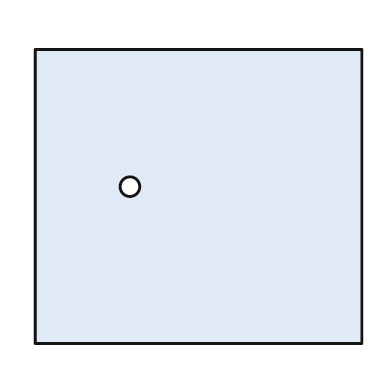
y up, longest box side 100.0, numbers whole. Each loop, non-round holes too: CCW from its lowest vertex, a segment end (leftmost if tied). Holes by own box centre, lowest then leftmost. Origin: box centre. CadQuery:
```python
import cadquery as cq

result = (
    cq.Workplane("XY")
    .moveTo(-50.0, -45.0)
    .lineTo(50.0, -45.0)
    .lineTo(50.0, 45.0)
    .lineTo(-50.0, 45.0)
    .close()
    .moveTo(-21.0, 3.0)
    .circle(3.0)
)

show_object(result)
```